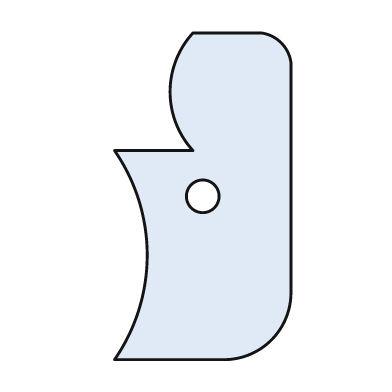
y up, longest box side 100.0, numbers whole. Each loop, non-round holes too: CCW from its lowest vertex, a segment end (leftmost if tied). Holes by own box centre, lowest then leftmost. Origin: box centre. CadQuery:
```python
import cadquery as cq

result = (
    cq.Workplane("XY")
    .moveTo(-27.0, -50.0)
    .lineTo(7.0, -50.0)
    .threePointArc((21.0, -44.0), (27.0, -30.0))
    .lineTo(27.0, 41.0)
    .threePointArc((24.0, 47.0), (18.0, 50.0))
    .lineTo(-3.0, 50.0)
    .threePointArc((-10.0, 32.0), (-3.0, 14.0))
    .lineTo(-27.0, 14.0)
    .threePointArc((-17.0, -18.0), (-27.0, -50.0))
    .close()
    .moveTo(0.0, 0.0)
    .circle(5.0)
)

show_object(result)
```